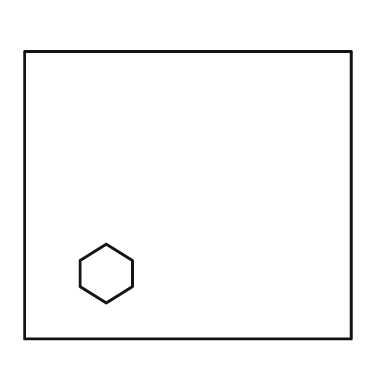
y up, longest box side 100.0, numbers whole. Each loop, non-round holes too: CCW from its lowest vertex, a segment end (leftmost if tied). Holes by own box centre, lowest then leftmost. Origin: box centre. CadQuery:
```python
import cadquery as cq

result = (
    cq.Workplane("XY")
    .moveTo(-50.0, -44.0)
    .lineTo(50.0, -44.0)
    .lineTo(50.0, 44.0)
    .lineTo(-50.0, 44.0)
    .close()
    .moveTo(-25.0, -33.0)
    .lineTo(-17.0, -28.0)
    .lineTo(-17.0, -20.0)
    .lineTo(-25.0, -15.0)
    .lineTo(-33.0, -20.0)
    .lineTo(-33.0, -28.0)
    .close()
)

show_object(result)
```